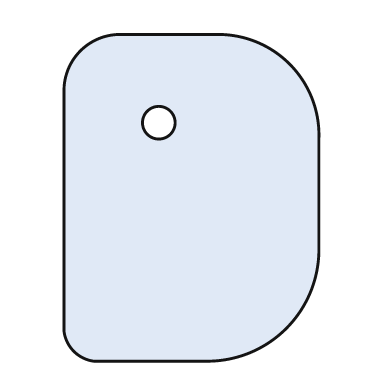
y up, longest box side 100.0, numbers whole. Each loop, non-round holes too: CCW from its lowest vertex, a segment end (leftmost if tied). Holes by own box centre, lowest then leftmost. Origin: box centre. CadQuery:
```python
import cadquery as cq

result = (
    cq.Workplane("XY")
    .moveTo(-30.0, -50.0)
    .lineTo(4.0, -50.0)
    .threePointArc((29.0, -40.0), (39.0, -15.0))
    .lineTo(39.0, 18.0)
    .threePointArc((30.0, 41.0), (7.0, 50.0))
    .lineTo(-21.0, 50.0)
    .threePointArc((-34.0, 45.0), (-39.0, 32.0))
    .lineTo(-39.0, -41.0)
    .threePointArc((-36.0, -47.0), (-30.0, -50.0))
    .close()
    .moveTo(-10.0, 23.0)
    .circle(5.0)
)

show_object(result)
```